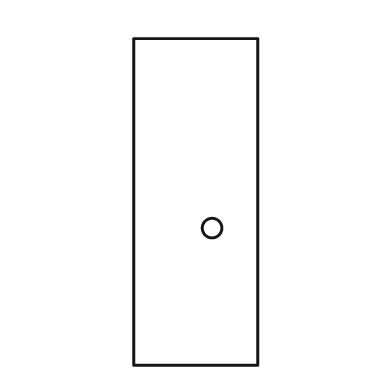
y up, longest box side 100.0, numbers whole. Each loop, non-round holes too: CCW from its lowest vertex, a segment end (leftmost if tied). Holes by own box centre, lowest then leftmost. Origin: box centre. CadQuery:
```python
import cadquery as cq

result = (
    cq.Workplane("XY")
    .moveTo(-19.0, -50.0)
    .lineTo(19.0, -50.0)
    .lineTo(19.0, 50.0)
    .lineTo(-19.0, 50.0)
    .close()
    .moveTo(5.0, -8.0)
    .circle(3.0)
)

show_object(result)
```